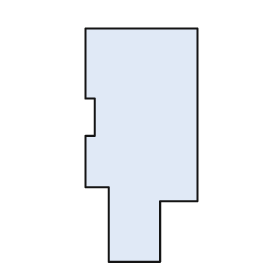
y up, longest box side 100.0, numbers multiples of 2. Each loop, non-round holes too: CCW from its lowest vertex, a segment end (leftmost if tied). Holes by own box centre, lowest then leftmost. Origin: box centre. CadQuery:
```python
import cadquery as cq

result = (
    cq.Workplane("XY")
    .moveTo(-14.0, -50.0)
    .lineTo(8.0, -50.0)
    .lineTo(8.0, -24.0)
    .lineTo(24.0, -24.0)
    .lineTo(24.0, 50.0)
    .lineTo(-24.0, 50.0)
    .lineTo(-24.0, 20.0)
    .lineTo(-20.0, 20.0)
    .lineTo(-20.0, 4.0)
    .lineTo(-24.0, 4.0)
    .lineTo(-24.0, -18.0)
    .lineTo(-14.0, -18.0)
    .close()
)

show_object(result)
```